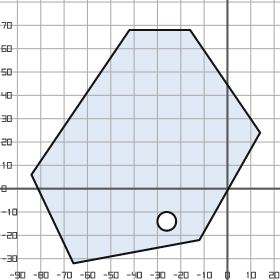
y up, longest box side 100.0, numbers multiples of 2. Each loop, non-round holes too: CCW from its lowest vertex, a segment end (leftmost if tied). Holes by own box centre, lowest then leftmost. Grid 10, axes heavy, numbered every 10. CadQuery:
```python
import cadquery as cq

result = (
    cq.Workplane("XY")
    .moveTo(-66.0, -32.0)
    .lineTo(-12.0, -22.0)
    .lineTo(14.0, 24.0)
    .lineTo(-16.0, 68.0)
    .lineTo(-42.0, 68.0)
    .lineTo(-84.0, 6.0)
    .close()
    .moveTo(-26.0, -14.0)
    .circle(4.0)
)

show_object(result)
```